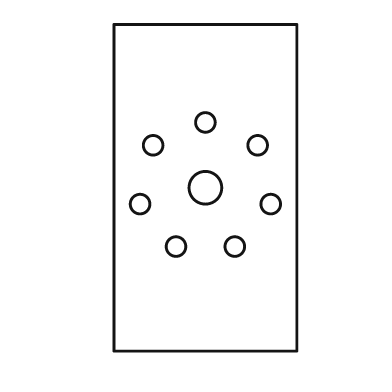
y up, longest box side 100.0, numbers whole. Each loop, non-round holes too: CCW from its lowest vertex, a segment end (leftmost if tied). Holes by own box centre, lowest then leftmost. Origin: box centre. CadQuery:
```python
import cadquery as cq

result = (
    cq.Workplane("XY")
    .moveTo(-28.0, -50.0)
    .lineTo(28.0, -50.0)
    .lineTo(28.0, 50.0)
    .lineTo(-28.0, 50.0)
    .close()
    .moveTo(-9.0, -18.0)
    .circle(3.0)
    .moveTo(9.0, -18.0)
    .circle(3.0)
    .moveTo(-20.0, -5.0)
    .circle(3.0)
    .moveTo(20.0, -5.0)
    .circle(3.0)
    .moveTo(0.0, 0.0)
    .circle(5.0)
    .moveTo(-16.0, 13.0)
    .circle(3.0)
    .moveTo(16.0, 13.0)
    .circle(3.0)
    .moveTo(0.0, 20.0)
    .circle(3.0)
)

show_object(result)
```